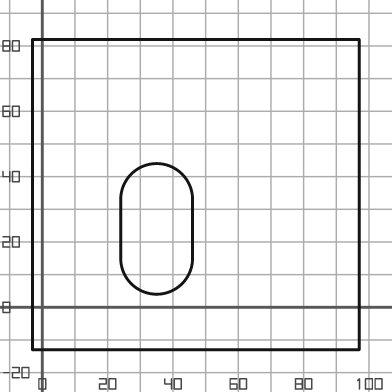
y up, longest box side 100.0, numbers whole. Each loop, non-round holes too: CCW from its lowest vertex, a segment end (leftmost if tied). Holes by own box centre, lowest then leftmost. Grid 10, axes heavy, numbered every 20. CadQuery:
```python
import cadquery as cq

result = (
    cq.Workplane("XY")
    .moveTo(-3.0, -13.0)
    .lineTo(97.0, -13.0)
    .lineTo(97.0, 82.0)
    .lineTo(-3.0, 82.0)
    .close()
    .moveTo(24.0, 15.0)
    .threePointArc((35.0, 4.0), (46.0, 15.0))
    .lineTo(46.0, 33.0)
    .threePointArc((35.0, 44.0), (24.0, 33.0))
    .close()
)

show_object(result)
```